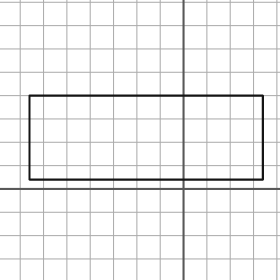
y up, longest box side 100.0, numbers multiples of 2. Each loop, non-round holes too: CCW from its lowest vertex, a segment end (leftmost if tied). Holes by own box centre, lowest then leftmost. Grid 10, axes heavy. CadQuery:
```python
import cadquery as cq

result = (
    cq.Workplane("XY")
    .moveTo(-66.0, 4.0)
    .lineTo(34.0, 4.0)
    .lineTo(34.0, 40.0)
    .lineTo(-66.0, 40.0)
    .close()
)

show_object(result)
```